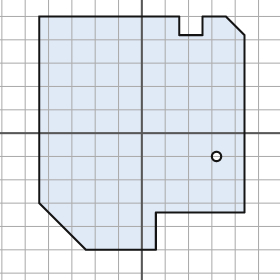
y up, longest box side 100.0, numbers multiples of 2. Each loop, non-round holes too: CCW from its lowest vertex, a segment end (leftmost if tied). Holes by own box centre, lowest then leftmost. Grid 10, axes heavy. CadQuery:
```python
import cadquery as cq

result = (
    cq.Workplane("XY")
    .moveTo(-24.0, -50.0)
    .lineTo(6.0, -50.0)
    .lineTo(6.0, -34.0)
    .lineTo(44.0, -34.0)
    .lineTo(44.0, 42.0)
    .lineTo(36.0, 50.0)
    .lineTo(26.0, 50.0)
    .lineTo(26.0, 42.0)
    .lineTo(16.0, 42.0)
    .lineTo(16.0, 50.0)
    .lineTo(-44.0, 50.0)
    .lineTo(-44.0, -30.0)
    .close()
    .moveTo(32.0, -10.0)
    .circle(2.0)
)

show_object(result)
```